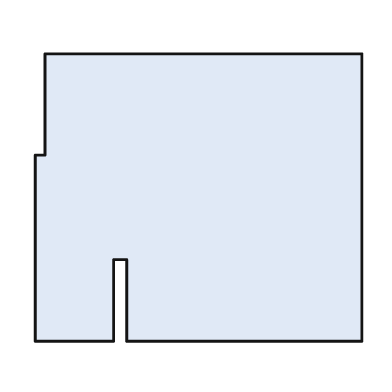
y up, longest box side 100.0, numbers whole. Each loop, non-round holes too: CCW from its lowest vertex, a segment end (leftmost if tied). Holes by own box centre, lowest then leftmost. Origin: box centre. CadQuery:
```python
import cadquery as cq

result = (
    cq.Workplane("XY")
    .moveTo(-50.0, -44.0)
    .lineTo(-26.0, -44.0)
    .lineTo(-26.0, -19.0)
    .lineTo(-22.0, -19.0)
    .lineTo(-22.0, -44.0)
    .lineTo(50.0, -44.0)
    .lineTo(50.0, 44.0)
    .lineTo(-47.0, 44.0)
    .lineTo(-47.0, 13.0)
    .lineTo(-50.0, 13.0)
    .close()
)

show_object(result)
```